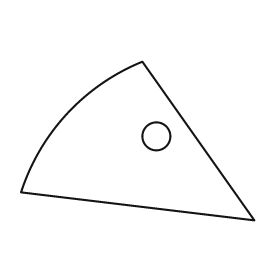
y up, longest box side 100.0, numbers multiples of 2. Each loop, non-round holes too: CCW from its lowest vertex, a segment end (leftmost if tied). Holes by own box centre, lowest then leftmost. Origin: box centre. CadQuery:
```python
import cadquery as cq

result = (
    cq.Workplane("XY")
    .moveTo(50.0, -34.0)
    .lineTo(2.0, 34.0)
    .threePointArc((-30.0, 12.0), (-50.0, -22.0))
    .close()
    .moveTo(8.0, 2.0)
    .circle(6.0)
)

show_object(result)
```